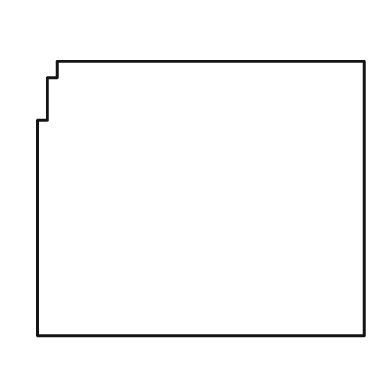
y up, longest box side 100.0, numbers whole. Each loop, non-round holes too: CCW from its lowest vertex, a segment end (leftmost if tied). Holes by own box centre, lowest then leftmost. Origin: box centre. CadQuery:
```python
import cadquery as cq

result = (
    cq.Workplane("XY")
    .moveTo(-50.0, -42.0)
    .lineTo(50.0, -42.0)
    .lineTo(50.0, 42.0)
    .lineTo(-44.0, 42.0)
    .lineTo(-44.0, 37.0)
    .lineTo(-47.0, 37.0)
    .lineTo(-47.0, 24.0)
    .lineTo(-50.0, 24.0)
    .close()
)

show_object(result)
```